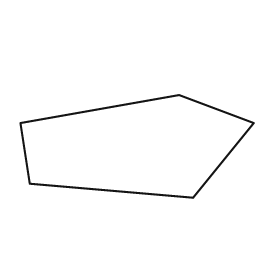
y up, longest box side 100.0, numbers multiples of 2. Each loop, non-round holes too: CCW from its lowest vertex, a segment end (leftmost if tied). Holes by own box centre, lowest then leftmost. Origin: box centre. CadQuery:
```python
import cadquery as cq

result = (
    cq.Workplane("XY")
    .moveTo(24.0, -22.0)
    .lineTo(50.0, 10.0)
    .lineTo(18.0, 22.0)
    .lineTo(-50.0, 10.0)
    .lineTo(-46.0, -16.0)
    .close()
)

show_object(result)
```